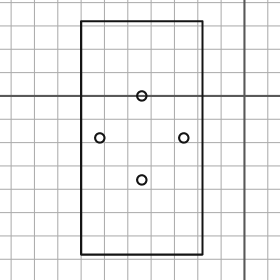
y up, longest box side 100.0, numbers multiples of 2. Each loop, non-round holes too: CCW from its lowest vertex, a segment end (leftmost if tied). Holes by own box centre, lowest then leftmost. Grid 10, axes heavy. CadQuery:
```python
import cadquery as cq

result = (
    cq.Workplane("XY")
    .moveTo(-70.0, -68.0)
    .lineTo(-18.0, -68.0)
    .lineTo(-18.0, 32.0)
    .lineTo(-70.0, 32.0)
    .close()
    .moveTo(-44.0, -36.0)
    .circle(2.0)
    .moveTo(-62.0, -18.0)
    .circle(2.0)
    .moveTo(-26.0, -18.0)
    .circle(2.0)
    .moveTo(-44.0, 0.0)
    .circle(2.0)
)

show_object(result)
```